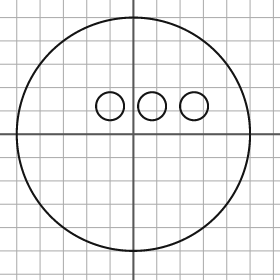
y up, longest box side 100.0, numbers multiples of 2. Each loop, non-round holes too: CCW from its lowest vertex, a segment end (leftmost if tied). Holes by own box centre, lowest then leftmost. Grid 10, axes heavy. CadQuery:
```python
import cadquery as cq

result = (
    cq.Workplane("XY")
    .moveTo(0.0, 0.0)
    .circle(50.0)
    .moveTo(-10.0, 12.0)
    .circle(6.0)
    .moveTo(8.0, 12.0)
    .circle(6.0)
    .moveTo(26.0, 12.0)
    .circle(6.0)
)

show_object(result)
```